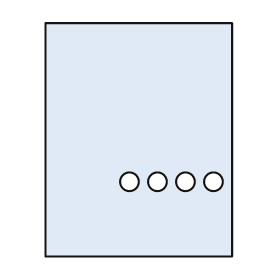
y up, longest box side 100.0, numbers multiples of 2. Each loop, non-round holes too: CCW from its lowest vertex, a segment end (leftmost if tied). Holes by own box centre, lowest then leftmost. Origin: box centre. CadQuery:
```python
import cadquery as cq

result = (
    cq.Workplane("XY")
    .moveTo(-40.0, -50.0)
    .lineTo(40.0, -50.0)
    .lineTo(40.0, 50.0)
    .lineTo(-40.0, 50.0)
    .close()
    .moveTo(-4.0, -18.0)
    .circle(4.0)
    .moveTo(8.0, -18.0)
    .circle(4.0)
    .moveTo(20.0, -18.0)
    .circle(4.0)
    .moveTo(32.0, -18.0)
    .circle(4.0)
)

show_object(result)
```